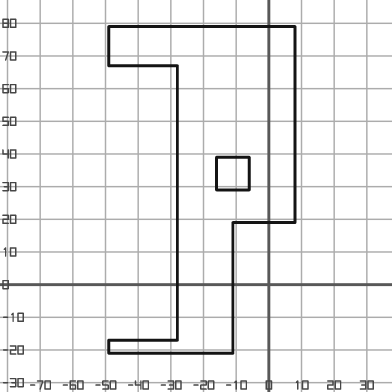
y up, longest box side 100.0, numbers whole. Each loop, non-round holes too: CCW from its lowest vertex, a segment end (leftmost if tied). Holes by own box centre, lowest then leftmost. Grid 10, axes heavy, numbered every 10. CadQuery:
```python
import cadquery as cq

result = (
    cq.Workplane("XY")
    .moveTo(-49.0, -21.0)
    .lineTo(-11.0, -21.0)
    .lineTo(-11.0, 19.0)
    .lineTo(8.0, 19.0)
    .lineTo(8.0, 79.0)
    .lineTo(-49.0, 79.0)
    .lineTo(-49.0, 67.0)
    .lineTo(-28.0, 67.0)
    .lineTo(-28.0, -17.0)
    .lineTo(-49.0, -17.0)
    .close()
    .moveTo(-16.0, 29.0)
    .lineTo(-6.0, 29.0)
    .lineTo(-6.0, 39.0)
    .lineTo(-16.0, 39.0)
    .close()
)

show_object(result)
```